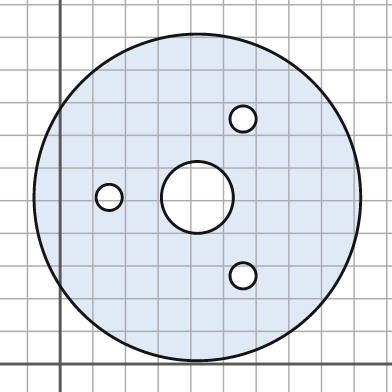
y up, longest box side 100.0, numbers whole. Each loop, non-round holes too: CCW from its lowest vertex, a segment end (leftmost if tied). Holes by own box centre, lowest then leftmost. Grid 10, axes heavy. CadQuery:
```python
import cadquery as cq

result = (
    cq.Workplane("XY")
    .moveTo(42.0, 51.0)
    .circle(50.0)
    .moveTo(56.0, 27.0)
    .circle(4.0)
    .moveTo(15.0, 51.0)
    .circle(4.0)
    .moveTo(42.0, 51.0)
    .circle(11.0)
    .moveTo(56.0, 75.0)
    .circle(4.0)
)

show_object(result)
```